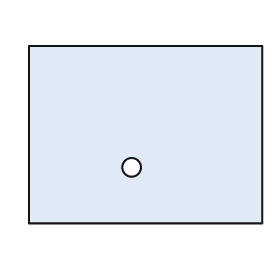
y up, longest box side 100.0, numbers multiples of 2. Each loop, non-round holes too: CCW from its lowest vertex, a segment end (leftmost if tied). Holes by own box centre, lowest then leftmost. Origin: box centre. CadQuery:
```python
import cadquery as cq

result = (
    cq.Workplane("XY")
    .moveTo(-50.0, -38.0)
    .lineTo(50.0, -38.0)
    .lineTo(50.0, 38.0)
    .lineTo(-50.0, 38.0)
    .close()
    .moveTo(-6.0, -14.0)
    .circle(4.0)
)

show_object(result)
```